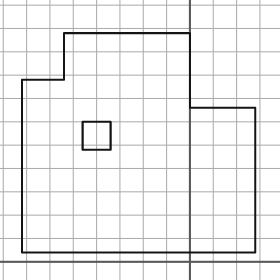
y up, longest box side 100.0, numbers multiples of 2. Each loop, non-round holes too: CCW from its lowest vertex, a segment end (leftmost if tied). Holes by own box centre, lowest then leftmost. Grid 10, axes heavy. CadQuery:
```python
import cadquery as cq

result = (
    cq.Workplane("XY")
    .moveTo(-72.0, 4.0)
    .lineTo(28.0, 4.0)
    .lineTo(28.0, 66.0)
    .lineTo(0.0, 66.0)
    .lineTo(0.0, 98.0)
    .lineTo(-54.0, 98.0)
    .lineTo(-54.0, 78.0)
    .lineTo(-72.0, 78.0)
    .close()
    .moveTo(-46.0, 48.0)
    .lineTo(-34.0, 48.0)
    .lineTo(-34.0, 60.0)
    .lineTo(-46.0, 60.0)
    .close()
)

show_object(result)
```